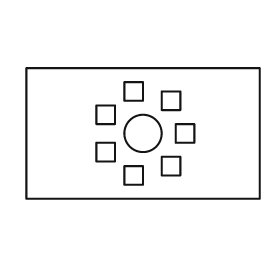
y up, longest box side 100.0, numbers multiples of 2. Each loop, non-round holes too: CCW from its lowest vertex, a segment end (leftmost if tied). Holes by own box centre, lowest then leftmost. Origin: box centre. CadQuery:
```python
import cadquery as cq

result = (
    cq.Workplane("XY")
    .moveTo(-50.0, -28.0)
    .lineTo(50.0, -28.0)
    .lineTo(50.0, 28.0)
    .lineTo(-50.0, 28.0)
    .close()
    .moveTo(-8.0, -22.0)
    .lineTo(0.0, -22.0)
    .lineTo(0.0, -14.0)
    .lineTo(-8.0, -14.0)
    .close()
    .moveTo(8.0, -18.0)
    .lineTo(16.0, -18.0)
    .lineTo(16.0, -10.0)
    .lineTo(8.0, -10.0)
    .close()
    .moveTo(-20.0, -12.0)
    .lineTo(-12.0, -12.0)
    .lineTo(-12.0, -4.0)
    .lineTo(-20.0, -4.0)
    .close()
    .moveTo(0.0, 0.0)
    .circle(8.0)
    .moveTo(14.0, -4.0)
    .lineTo(22.0, -4.0)
    .lineTo(22.0, 4.0)
    .lineTo(14.0, 4.0)
    .close()
    .moveTo(-20.0, 4.0)
    .lineTo(-12.0, 4.0)
    .lineTo(-12.0, 12.0)
    .lineTo(-20.0, 12.0)
    .close()
    .moveTo(8.0, 10.0)
    .lineTo(16.0, 10.0)
    .lineTo(16.0, 18.0)
    .lineTo(8.0, 18.0)
    .close()
    .moveTo(-8.0, 14.0)
    .lineTo(0.0, 14.0)
    .lineTo(0.0, 22.0)
    .lineTo(-8.0, 22.0)
    .close()
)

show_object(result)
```